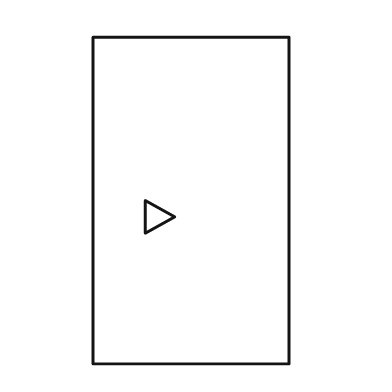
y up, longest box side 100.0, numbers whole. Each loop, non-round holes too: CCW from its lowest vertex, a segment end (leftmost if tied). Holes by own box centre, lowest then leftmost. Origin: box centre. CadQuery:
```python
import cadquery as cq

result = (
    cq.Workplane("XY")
    .moveTo(-30.0, -50.0)
    .lineTo(30.0, -50.0)
    .lineTo(30.0, 50.0)
    .lineTo(-30.0, 50.0)
    .close()
    .moveTo(-14.0, -10.0)
    .lineTo(-5.0, -5.0)
    .lineTo(-14.0, 0.0)
    .close()
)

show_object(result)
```